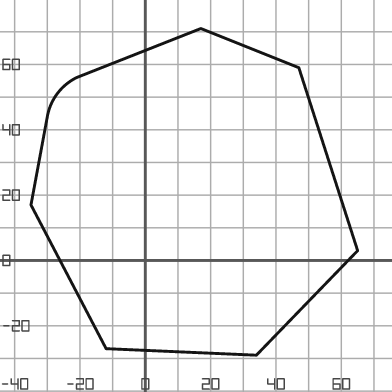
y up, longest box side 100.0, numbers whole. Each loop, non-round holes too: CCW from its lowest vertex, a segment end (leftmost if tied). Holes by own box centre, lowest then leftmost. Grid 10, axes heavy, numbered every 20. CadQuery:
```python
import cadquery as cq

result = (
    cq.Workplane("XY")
    .moveTo(34.0, -29.0)
    .lineTo(65.0, 3.0)
    .lineTo(47.0, 59.0)
    .lineTo(17.0, 71.0)
    .lineTo(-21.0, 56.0)
    .threePointArc((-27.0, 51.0), (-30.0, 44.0))
    .lineTo(-35.0, 17.0)
    .lineTo(-12.0, -27.0)
    .close()
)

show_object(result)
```